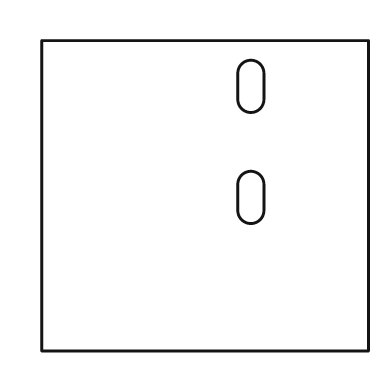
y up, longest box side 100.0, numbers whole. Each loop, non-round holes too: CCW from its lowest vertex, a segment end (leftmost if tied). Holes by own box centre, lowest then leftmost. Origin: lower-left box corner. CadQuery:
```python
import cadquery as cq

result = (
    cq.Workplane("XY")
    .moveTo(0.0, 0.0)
    .lineTo(100.0, 0.0)
    .lineTo(100.0, 95.0)
    .lineTo(0.0, 95.0)
    .close()
    .moveTo(60.0, 43.0)
    .threePointArc((64.0, 39.0), (68.0, 43.0))
    .lineTo(68.0, 51.0)
    .threePointArc((64.0, 55.0), (60.0, 51.0))
    .close()
    .moveTo(60.0, 77.0)
    .threePointArc((64.0, 73.0), (68.0, 77.0))
    .lineTo(68.0, 85.0)
    .threePointArc((64.0, 89.0), (60.0, 85.0))
    .close()
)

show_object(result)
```